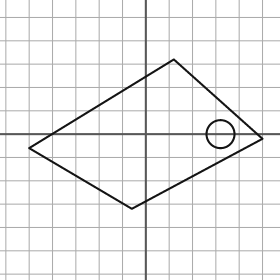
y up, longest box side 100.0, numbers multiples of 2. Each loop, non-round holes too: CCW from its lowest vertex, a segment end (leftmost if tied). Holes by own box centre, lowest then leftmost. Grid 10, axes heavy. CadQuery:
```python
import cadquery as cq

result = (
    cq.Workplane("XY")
    .moveTo(-6.0, -32.0)
    .lineTo(50.0, -2.0)
    .lineTo(12.0, 32.0)
    .lineTo(-50.0, -6.0)
    .close()
    .moveTo(32.0, 0.0)
    .circle(6.0)
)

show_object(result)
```